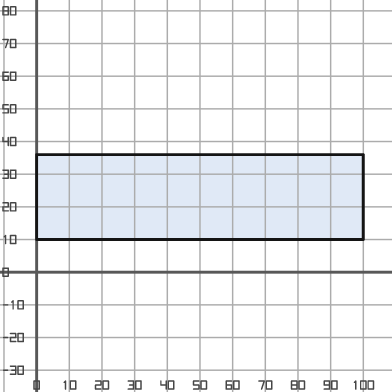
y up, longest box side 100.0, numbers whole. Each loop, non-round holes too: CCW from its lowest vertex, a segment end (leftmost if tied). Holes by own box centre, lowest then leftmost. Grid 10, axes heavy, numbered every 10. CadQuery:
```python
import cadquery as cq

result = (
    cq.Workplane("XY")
    .moveTo(0.0, 10.0)
    .lineTo(100.0, 10.0)
    .lineTo(100.0, 36.0)
    .lineTo(0.0, 36.0)
    .close()
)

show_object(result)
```